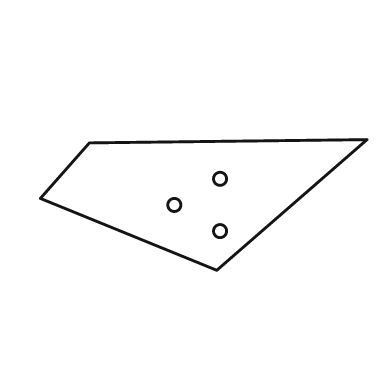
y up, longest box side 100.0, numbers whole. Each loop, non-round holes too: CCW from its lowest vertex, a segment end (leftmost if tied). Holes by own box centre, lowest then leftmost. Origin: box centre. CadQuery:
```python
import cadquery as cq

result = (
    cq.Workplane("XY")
    .moveTo(4.0, -20.0)
    .lineTo(50.0, 20.0)
    .lineTo(-35.0, 19.0)
    .lineTo(-50.0, 2.0)
    .close()
    .moveTo(5.0, -8.0)
    .circle(2.0)
    .moveTo(-9.0, 0.0)
    .circle(2.0)
    .moveTo(5.0, 8.0)
    .circle(2.0)
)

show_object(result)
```